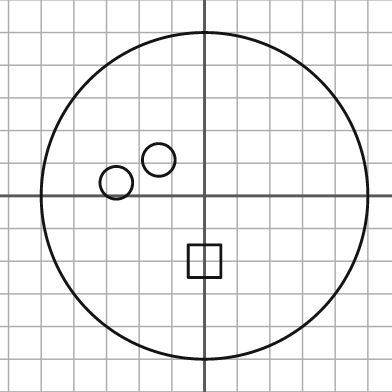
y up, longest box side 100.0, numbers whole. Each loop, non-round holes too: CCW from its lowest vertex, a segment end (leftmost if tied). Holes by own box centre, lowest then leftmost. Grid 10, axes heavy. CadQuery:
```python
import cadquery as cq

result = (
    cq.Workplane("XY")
    .moveTo(0.0, 0.0)
    .circle(50.0)
    .moveTo(-5.0, -25.0)
    .lineTo(5.0, -25.0)
    .lineTo(5.0, -15.0)
    .lineTo(-5.0, -15.0)
    .close()
    .moveTo(-27.0, 4.0)
    .circle(5.0)
    .moveTo(-14.0, 11.0)
    .circle(5.0)
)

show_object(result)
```